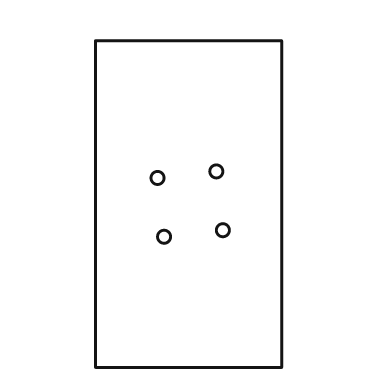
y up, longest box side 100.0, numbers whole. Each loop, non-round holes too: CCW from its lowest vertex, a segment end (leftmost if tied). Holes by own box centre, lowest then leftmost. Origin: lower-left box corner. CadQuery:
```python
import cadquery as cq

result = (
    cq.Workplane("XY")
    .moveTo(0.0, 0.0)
    .lineTo(57.0, 0.0)
    .lineTo(57.0, 100.0)
    .lineTo(0.0, 100.0)
    .close()
    .moveTo(21.0, 40.0)
    .circle(2.0)
    .moveTo(39.0, 42.0)
    .circle(2.0)
    .moveTo(19.0, 58.0)
    .circle(2.0)
    .moveTo(37.0, 60.0)
    .circle(2.0)
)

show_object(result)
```